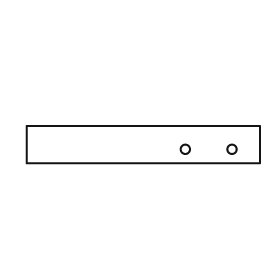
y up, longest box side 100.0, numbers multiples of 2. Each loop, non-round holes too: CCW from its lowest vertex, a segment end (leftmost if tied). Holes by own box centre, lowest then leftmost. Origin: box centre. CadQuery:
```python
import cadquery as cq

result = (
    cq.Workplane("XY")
    .moveTo(-50.0, -8.0)
    .lineTo(50.0, -8.0)
    .lineTo(50.0, 8.0)
    .lineTo(-50.0, 8.0)
    .close()
    .moveTo(18.0, -2.0)
    .circle(2.0)
    .moveTo(38.0, -2.0)
    .circle(2.0)
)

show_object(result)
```